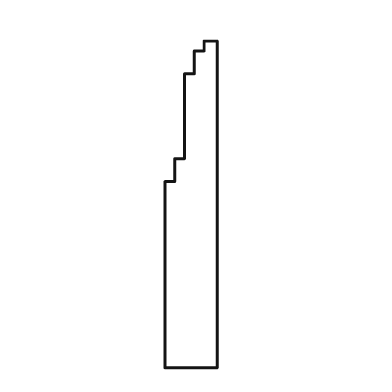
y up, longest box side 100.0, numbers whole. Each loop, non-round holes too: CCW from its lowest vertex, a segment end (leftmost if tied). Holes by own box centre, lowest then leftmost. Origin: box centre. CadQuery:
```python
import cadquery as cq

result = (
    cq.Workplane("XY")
    .moveTo(-8.0, -50.0)
    .lineTo(8.0, -50.0)
    .lineTo(8.0, 50.0)
    .lineTo(4.0, 50.0)
    .lineTo(4.0, 47.0)
    .lineTo(1.0, 47.0)
    .lineTo(1.0, 40.0)
    .lineTo(-2.0, 40.0)
    .lineTo(-2.0, 14.0)
    .lineTo(-5.0, 14.0)
    .lineTo(-5.0, 7.0)
    .lineTo(-8.0, 7.0)
    .close()
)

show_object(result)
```